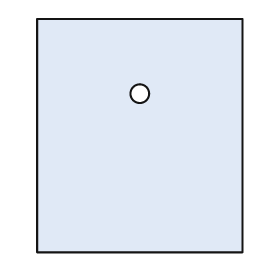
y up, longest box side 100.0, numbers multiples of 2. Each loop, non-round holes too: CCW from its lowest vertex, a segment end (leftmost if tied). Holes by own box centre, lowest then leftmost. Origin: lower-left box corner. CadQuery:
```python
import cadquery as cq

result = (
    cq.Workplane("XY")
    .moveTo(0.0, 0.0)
    .lineTo(88.0, 0.0)
    .lineTo(88.0, 100.0)
    .lineTo(0.0, 100.0)
    .close()
    .moveTo(44.0, 68.0)
    .circle(4.0)
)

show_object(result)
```